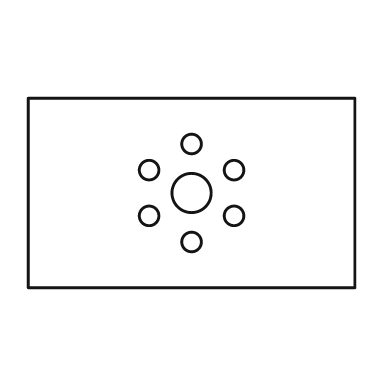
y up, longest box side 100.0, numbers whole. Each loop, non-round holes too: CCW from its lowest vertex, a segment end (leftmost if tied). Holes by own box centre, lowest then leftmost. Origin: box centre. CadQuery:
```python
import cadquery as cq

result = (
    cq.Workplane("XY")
    .moveTo(-50.0, -29.0)
    .lineTo(50.0, -29.0)
    .lineTo(50.0, 29.0)
    .lineTo(-50.0, 29.0)
    .close()
    .moveTo(0.0, -15.0)
    .circle(3.0)
    .moveTo(-13.0, -7.0)
    .circle(3.0)
    .moveTo(13.0, -7.0)
    .circle(3.0)
    .moveTo(0.0, 0.0)
    .circle(6.0)
    .moveTo(-13.0, 7.0)
    .circle(3.0)
    .moveTo(13.0, 7.0)
    .circle(3.0)
    .moveTo(0.0, 15.0)
    .circle(3.0)
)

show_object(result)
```